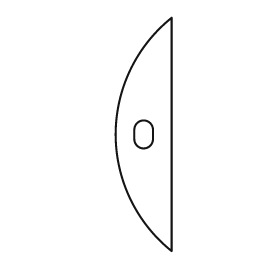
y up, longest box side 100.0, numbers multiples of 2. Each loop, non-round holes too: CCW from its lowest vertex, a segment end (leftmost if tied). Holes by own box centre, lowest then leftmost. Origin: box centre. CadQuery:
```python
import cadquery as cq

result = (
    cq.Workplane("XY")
    .moveTo(12.0, -50.0)
    .lineTo(12.0, 50.0)
    .threePointArc((-12.0, 0.0), (12.0, -50.0))
    .close()
    .moveTo(-4.0, -2.0)
    .threePointArc((0.0, -6.0), (4.0, -2.0))
    .lineTo(4.0, 2.0)
    .threePointArc((0.0, 6.0), (-4.0, 2.0))
    .close()
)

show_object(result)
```